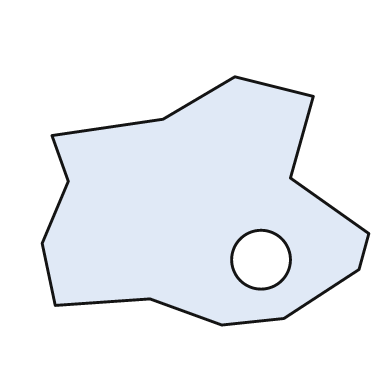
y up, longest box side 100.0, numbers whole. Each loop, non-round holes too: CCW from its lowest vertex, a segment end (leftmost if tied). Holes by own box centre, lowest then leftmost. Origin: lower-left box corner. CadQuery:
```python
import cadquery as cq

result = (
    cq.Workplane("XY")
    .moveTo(55.0, 0.0)
    .lineTo(74.0, 2.0)
    .lineTo(97.0, 17.0)
    .lineTo(100.0, 28.0)
    .lineTo(76.0, 45.0)
    .lineTo(83.0, 70.0)
    .lineTo(59.0, 76.0)
    .lineTo(37.0, 63.0)
    .lineTo(3.0, 58.0)
    .lineTo(8.0, 44.0)
    .lineTo(0.0, 25.0)
    .lineTo(4.0, 6.0)
    .lineTo(33.0, 8.0)
    .close()
    .moveTo(67.0, 20.0)
    .circle(9.0)
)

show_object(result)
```